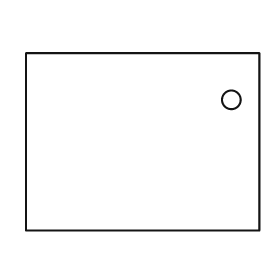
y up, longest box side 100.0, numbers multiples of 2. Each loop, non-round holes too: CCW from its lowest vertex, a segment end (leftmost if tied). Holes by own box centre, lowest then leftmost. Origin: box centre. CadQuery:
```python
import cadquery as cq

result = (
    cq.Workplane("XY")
    .moveTo(-50.0, -38.0)
    .lineTo(50.0, -38.0)
    .lineTo(50.0, 38.0)
    .lineTo(-50.0, 38.0)
    .close()
    .moveTo(38.0, 18.0)
    .circle(4.0)
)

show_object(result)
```